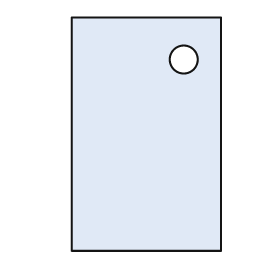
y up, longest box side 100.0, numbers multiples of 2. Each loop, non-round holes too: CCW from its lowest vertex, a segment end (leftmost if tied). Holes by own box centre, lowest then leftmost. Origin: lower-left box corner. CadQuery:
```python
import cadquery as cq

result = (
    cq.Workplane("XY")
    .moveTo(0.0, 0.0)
    .lineTo(64.0, 0.0)
    .lineTo(64.0, 100.0)
    .lineTo(0.0, 100.0)
    .close()
    .moveTo(48.0, 82.0)
    .circle(6.0)
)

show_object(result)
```